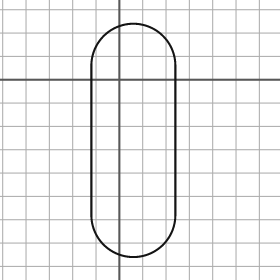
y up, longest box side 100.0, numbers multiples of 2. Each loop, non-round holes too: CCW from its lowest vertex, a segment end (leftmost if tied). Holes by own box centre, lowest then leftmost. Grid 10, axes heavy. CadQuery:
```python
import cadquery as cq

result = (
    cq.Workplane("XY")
    .moveTo(-12.0, -58.0)
    .threePointArc((6.0, -76.0), (24.0, -58.0))
    .lineTo(24.0, 6.0)
    .threePointArc((6.0, 24.0), (-12.0, 6.0))
    .close()
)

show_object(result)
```